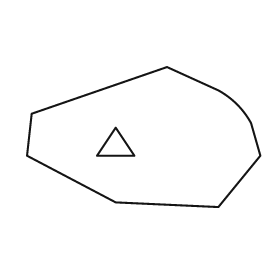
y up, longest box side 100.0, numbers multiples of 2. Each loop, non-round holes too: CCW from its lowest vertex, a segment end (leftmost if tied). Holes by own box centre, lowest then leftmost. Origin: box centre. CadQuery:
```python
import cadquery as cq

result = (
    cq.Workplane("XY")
    .moveTo(32.0, -30.0)
    .lineTo(50.0, -8.0)
    .lineTo(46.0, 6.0)
    .threePointArc((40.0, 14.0), (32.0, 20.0))
    .lineTo(10.0, 30.0)
    .lineTo(-48.0, 10.0)
    .lineTo(-50.0, -8.0)
    .lineTo(-12.0, -28.0)
    .close()
    .moveTo(-20.0, -8.0)
    .lineTo(-4.0, -8.0)
    .lineTo(-12.0, 4.0)
    .close()
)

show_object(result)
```